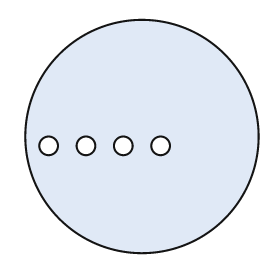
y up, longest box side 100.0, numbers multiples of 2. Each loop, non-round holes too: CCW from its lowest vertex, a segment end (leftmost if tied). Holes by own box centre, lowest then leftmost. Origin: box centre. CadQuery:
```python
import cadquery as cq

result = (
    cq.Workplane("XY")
    .moveTo(0.0, 0.0)
    .circle(50.0)
    .moveTo(-40.0, -4.0)
    .circle(4.0)
    .moveTo(-24.0, -4.0)
    .circle(4.0)
    .moveTo(-8.0, -4.0)
    .circle(4.0)
    .moveTo(8.0, -4.0)
    .circle(4.0)
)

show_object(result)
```